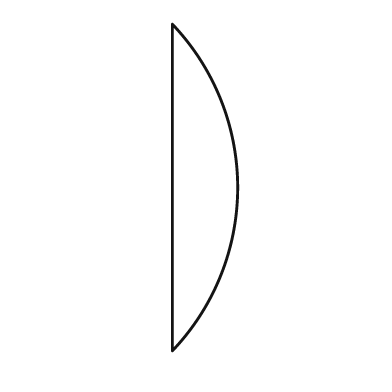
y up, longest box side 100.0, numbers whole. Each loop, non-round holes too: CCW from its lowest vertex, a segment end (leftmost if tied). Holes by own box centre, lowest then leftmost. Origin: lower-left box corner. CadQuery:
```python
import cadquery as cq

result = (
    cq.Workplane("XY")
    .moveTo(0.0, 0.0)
    .threePointArc((20.0, 50.0), (0.0, 100.0))
    .close()
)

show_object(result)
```